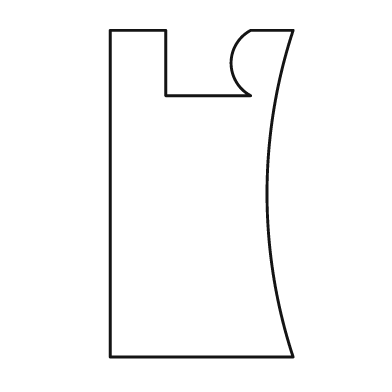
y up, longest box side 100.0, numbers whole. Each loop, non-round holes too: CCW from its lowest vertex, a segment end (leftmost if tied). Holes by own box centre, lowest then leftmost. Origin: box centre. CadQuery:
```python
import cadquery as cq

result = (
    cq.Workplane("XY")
    .moveTo(-28.0, -50.0)
    .lineTo(28.0, -50.0)
    .threePointArc((20.0, 0.0), (28.0, 50.0))
    .lineTo(15.0, 50.0)
    .threePointArc((9.0, 40.0), (15.0, 30.0))
    .lineTo(-11.0, 30.0)
    .lineTo(-11.0, 50.0)
    .lineTo(-28.0, 50.0)
    .close()
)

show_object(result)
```